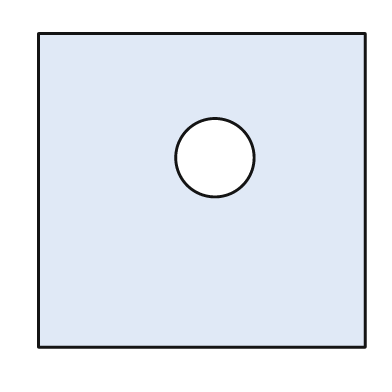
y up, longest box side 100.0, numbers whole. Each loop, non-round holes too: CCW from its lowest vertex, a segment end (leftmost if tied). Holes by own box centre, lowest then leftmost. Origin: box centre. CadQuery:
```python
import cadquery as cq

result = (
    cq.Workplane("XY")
    .moveTo(-50.0, -48.0)
    .lineTo(50.0, -48.0)
    .lineTo(50.0, 48.0)
    .lineTo(-50.0, 48.0)
    .close()
    .moveTo(4.0, 10.0)
    .circle(12.0)
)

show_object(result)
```